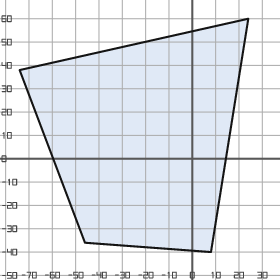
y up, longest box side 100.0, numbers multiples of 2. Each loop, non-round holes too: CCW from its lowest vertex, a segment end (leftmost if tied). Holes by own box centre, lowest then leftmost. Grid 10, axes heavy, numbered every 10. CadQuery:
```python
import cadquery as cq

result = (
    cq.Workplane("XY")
    .moveTo(8.0, -40.0)
    .lineTo(24.0, 60.0)
    .lineTo(-74.0, 38.0)
    .lineTo(-46.0, -36.0)
    .close()
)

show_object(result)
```